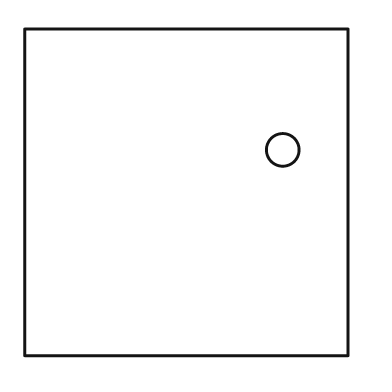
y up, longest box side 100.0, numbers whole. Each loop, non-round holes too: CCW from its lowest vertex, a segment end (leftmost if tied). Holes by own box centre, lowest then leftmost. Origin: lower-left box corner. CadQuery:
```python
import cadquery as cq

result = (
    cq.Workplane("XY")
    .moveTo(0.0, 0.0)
    .lineTo(99.0, 0.0)
    .lineTo(99.0, 100.0)
    .lineTo(0.0, 100.0)
    .close()
    .moveTo(79.0, 63.0)
    .circle(5.0)
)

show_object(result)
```